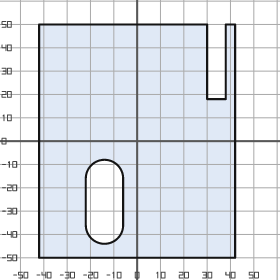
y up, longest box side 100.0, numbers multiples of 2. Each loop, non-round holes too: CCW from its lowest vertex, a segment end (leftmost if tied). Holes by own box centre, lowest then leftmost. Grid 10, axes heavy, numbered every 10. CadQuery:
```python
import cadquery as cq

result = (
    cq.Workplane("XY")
    .moveTo(-42.0, -50.0)
    .lineTo(42.0, -50.0)
    .lineTo(42.0, 50.0)
    .lineTo(38.0, 50.0)
    .lineTo(38.0, 18.0)
    .lineTo(30.0, 18.0)
    .lineTo(30.0, 50.0)
    .lineTo(-42.0, 50.0)
    .close()
    .moveTo(-22.0, -36.0)
    .threePointArc((-14.0, -44.0), (-6.0, -36.0))
    .lineTo(-6.0, -16.0)
    .threePointArc((-14.0, -8.0), (-22.0, -16.0))
    .close()
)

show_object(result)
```